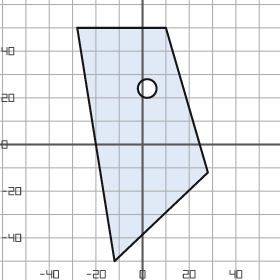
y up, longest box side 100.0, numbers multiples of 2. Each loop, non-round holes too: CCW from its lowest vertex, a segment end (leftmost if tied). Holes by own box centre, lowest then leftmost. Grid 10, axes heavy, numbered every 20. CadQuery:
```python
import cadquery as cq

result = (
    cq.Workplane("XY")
    .moveTo(-12.0, -50.0)
    .lineTo(28.0, -12.0)
    .lineTo(10.0, 50.0)
    .lineTo(-28.0, 50.0)
    .close()
    .moveTo(2.0, 24.0)
    .circle(4.0)
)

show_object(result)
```